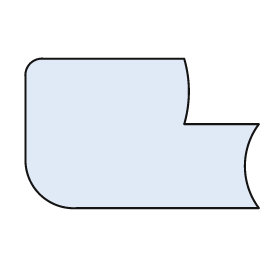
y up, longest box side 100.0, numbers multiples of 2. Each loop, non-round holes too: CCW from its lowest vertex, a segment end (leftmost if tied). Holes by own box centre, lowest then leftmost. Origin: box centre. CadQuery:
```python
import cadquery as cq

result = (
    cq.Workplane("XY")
    .moveTo(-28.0, -32.0)
    .lineTo(50.0, -32.0)
    .threePointArc((44.0, -14.0), (50.0, 4.0))
    .lineTo(18.0, 4.0)
    .threePointArc((20.0, 18.0), (18.0, 32.0))
    .lineTo(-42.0, 32.0)
    .threePointArc((-48.0, 30.0), (-50.0, 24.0))
    .lineTo(-50.0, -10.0)
    .threePointArc((-44.0, -26.0), (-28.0, -32.0))
    .close()
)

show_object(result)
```